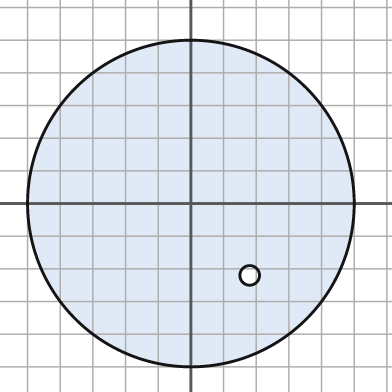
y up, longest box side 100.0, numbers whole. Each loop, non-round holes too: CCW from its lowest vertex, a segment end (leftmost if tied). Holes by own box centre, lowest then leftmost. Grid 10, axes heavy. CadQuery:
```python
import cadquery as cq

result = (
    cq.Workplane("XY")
    .moveTo(0.0, 0.0)
    .circle(50.0)
    .moveTo(18.0, -22.0)
    .circle(3.0)
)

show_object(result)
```